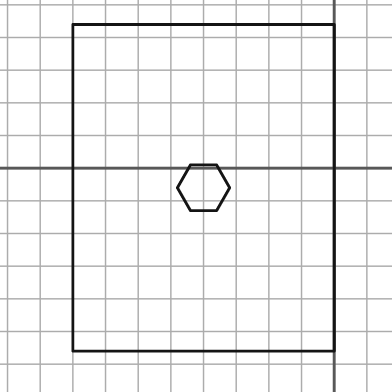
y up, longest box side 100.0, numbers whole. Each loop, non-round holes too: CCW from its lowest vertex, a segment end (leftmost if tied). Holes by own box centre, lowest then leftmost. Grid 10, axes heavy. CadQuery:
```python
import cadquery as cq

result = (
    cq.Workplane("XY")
    .moveTo(-80.0, -56.0)
    .lineTo(0.0, -56.0)
    .lineTo(0.0, 44.0)
    .lineTo(-80.0, 44.0)
    .close()
    .moveTo(-44.0, -13.0)
    .lineTo(-36.0, -13.0)
    .lineTo(-32.0, -6.0)
    .lineTo(-36.0, 1.0)
    .lineTo(-44.0, 1.0)
    .lineTo(-48.0, -6.0)
    .close()
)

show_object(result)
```